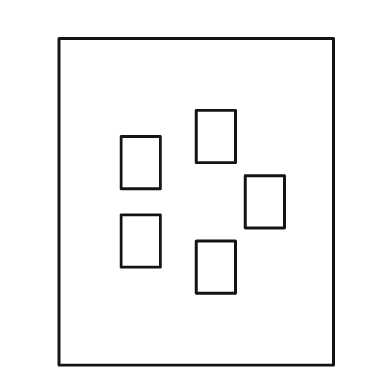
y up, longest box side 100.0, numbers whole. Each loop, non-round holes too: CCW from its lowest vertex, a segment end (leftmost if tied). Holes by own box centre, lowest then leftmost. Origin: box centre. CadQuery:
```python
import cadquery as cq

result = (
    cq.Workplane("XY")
    .moveTo(-42.0, -50.0)
    .lineTo(42.0, -50.0)
    .lineTo(42.0, 50.0)
    .lineTo(-42.0, 50.0)
    .close()
    .moveTo(0.0, -28.0)
    .lineTo(12.0, -28.0)
    .lineTo(12.0, -12.0)
    .lineTo(0.0, -12.0)
    .close()
    .moveTo(-23.0, -20.0)
    .lineTo(-11.0, -20.0)
    .lineTo(-11.0, -4.0)
    .lineTo(-23.0, -4.0)
    .close()
    .moveTo(15.0, -8.0)
    .lineTo(27.0, -8.0)
    .lineTo(27.0, 8.0)
    .lineTo(15.0, 8.0)
    .close()
    .moveTo(-23.0, 4.0)
    .lineTo(-11.0, 4.0)
    .lineTo(-11.0, 20.0)
    .lineTo(-23.0, 20.0)
    .close()
    .moveTo(0.0, 12.0)
    .lineTo(12.0, 12.0)
    .lineTo(12.0, 28.0)
    .lineTo(0.0, 28.0)
    .close()
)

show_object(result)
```